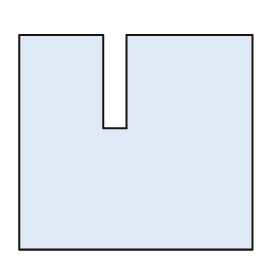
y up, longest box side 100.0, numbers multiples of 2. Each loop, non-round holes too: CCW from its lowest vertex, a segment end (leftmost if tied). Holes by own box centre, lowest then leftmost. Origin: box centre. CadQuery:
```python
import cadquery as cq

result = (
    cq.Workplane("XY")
    .moveTo(-50.0, -46.0)
    .lineTo(50.0, -46.0)
    .lineTo(50.0, 46.0)
    .lineTo(-4.0, 46.0)
    .lineTo(-4.0, 6.0)
    .lineTo(-14.0, 6.0)
    .lineTo(-14.0, 46.0)
    .lineTo(-50.0, 46.0)
    .close()
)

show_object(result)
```